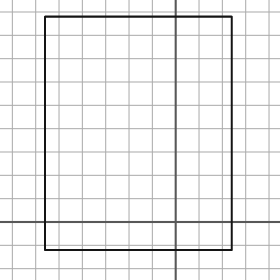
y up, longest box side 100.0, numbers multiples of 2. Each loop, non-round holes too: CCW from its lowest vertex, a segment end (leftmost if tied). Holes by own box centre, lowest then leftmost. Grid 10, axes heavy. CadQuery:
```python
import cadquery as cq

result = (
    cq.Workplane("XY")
    .moveTo(-56.0, -12.0)
    .lineTo(24.0, -12.0)
    .lineTo(24.0, 88.0)
    .lineTo(-56.0, 88.0)
    .close()
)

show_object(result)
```